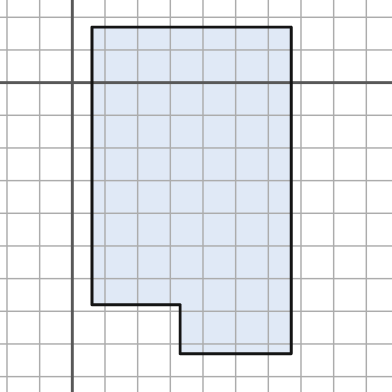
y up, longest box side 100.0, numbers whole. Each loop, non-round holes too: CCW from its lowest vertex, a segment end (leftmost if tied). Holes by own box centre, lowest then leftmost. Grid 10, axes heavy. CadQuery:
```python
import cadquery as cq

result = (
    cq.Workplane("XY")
    .moveTo(33.0, -83.0)
    .lineTo(67.0, -83.0)
    .lineTo(67.0, 17.0)
    .lineTo(6.0, 17.0)
    .lineTo(6.0, -68.0)
    .lineTo(33.0, -68.0)
    .close()
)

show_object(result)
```